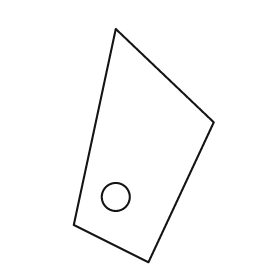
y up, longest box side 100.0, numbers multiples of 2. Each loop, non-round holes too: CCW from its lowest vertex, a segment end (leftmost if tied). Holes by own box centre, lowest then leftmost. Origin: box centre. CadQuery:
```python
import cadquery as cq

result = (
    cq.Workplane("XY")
    .moveTo(2.0, -50.0)
    .lineTo(30.0, 10.0)
    .lineTo(-12.0, 50.0)
    .lineTo(-30.0, -34.0)
    .close()
    .moveTo(-12.0, -22.0)
    .circle(6.0)
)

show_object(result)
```